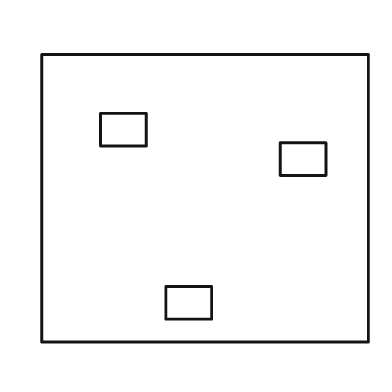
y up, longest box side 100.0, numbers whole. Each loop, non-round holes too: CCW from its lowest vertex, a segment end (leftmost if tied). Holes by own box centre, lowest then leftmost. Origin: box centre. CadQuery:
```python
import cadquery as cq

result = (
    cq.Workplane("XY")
    .moveTo(-50.0, -44.0)
    .lineTo(50.0, -44.0)
    .lineTo(50.0, 44.0)
    .lineTo(-50.0, 44.0)
    .close()
    .moveTo(-12.0, -37.0)
    .lineTo(2.0, -37.0)
    .lineTo(2.0, -27.0)
    .lineTo(-12.0, -27.0)
    .close()
    .moveTo(23.0, 7.0)
    .lineTo(37.0, 7.0)
    .lineTo(37.0, 17.0)
    .lineTo(23.0, 17.0)
    .close()
    .moveTo(-32.0, 16.0)
    .lineTo(-18.0, 16.0)
    .lineTo(-18.0, 26.0)
    .lineTo(-32.0, 26.0)
    .close()
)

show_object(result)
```